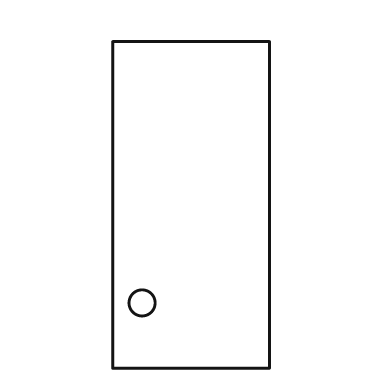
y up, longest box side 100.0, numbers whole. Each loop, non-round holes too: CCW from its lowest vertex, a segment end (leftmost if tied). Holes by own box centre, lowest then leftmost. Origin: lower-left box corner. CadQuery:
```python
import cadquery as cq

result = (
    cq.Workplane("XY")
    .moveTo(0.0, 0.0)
    .lineTo(48.0, 0.0)
    .lineTo(48.0, 100.0)
    .lineTo(0.0, 100.0)
    .close()
    .moveTo(9.0, 20.0)
    .circle(4.0)
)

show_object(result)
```